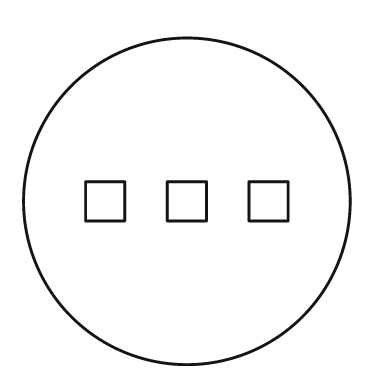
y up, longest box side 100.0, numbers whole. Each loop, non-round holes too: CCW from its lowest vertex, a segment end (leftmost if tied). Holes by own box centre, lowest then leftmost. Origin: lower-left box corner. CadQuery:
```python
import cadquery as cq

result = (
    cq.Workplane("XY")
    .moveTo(50.0, 50.0)
    .circle(50.0)
    .moveTo(19.0, 44.0)
    .lineTo(31.0, 44.0)
    .lineTo(31.0, 56.0)
    .lineTo(19.0, 56.0)
    .close()
    .moveTo(44.0, 44.0)
    .lineTo(56.0, 44.0)
    .lineTo(56.0, 56.0)
    .lineTo(44.0, 56.0)
    .close()
    .moveTo(69.0, 44.0)
    .lineTo(81.0, 44.0)
    .lineTo(81.0, 56.0)
    .lineTo(69.0, 56.0)
    .close()
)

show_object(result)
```